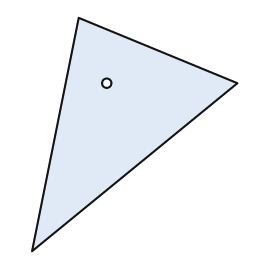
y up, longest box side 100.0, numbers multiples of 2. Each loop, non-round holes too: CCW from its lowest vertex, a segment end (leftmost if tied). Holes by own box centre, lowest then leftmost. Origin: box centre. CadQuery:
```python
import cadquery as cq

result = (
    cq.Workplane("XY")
    .moveTo(-44.0, -50.0)
    .lineTo(44.0, 22.0)
    .lineTo(-24.0, 50.0)
    .close()
    .moveTo(-12.0, 22.0)
    .circle(2.0)
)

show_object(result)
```